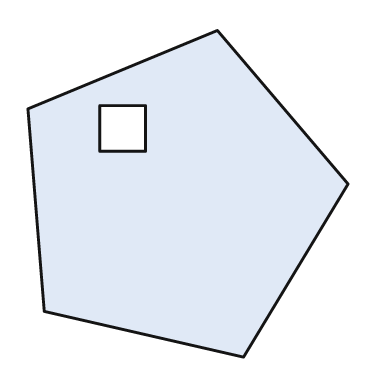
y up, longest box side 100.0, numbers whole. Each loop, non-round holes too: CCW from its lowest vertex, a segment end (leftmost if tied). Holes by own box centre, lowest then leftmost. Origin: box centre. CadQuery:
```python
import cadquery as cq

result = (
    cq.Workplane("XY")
    .moveTo(17.0, -50.0)
    .lineTo(49.0, 3.0)
    .lineTo(9.0, 50.0)
    .lineTo(-49.0, 26.0)
    .lineTo(-44.0, -36.0)
    .close()
    .moveTo(-27.0, 13.0)
    .lineTo(-13.0, 13.0)
    .lineTo(-13.0, 27.0)
    .lineTo(-27.0, 27.0)
    .close()
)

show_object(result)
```